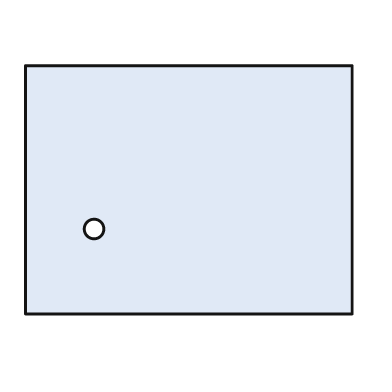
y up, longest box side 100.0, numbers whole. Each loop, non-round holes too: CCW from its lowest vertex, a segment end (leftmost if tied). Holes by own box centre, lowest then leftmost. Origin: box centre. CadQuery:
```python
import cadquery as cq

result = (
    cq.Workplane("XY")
    .moveTo(-50.0, -38.0)
    .lineTo(50.0, -38.0)
    .lineTo(50.0, 38.0)
    .lineTo(-50.0, 38.0)
    .close()
    .moveTo(-29.0, -12.0)
    .circle(3.0)
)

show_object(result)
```